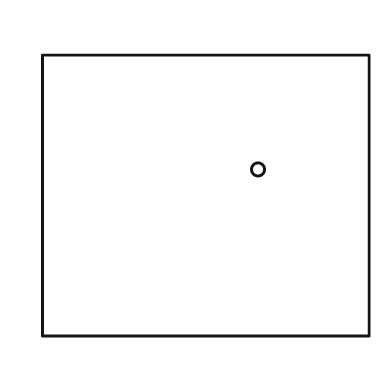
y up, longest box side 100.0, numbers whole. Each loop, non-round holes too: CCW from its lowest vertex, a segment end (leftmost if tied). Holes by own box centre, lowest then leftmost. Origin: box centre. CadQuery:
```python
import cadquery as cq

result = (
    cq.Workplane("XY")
    .moveTo(-50.0, -43.0)
    .lineTo(50.0, -43.0)
    .lineTo(50.0, 43.0)
    .lineTo(-50.0, 43.0)
    .close()
    .moveTo(16.0, 8.0)
    .circle(2.0)
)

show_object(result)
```